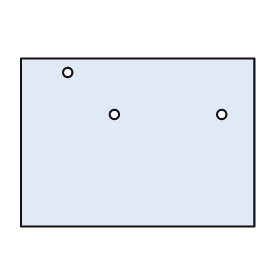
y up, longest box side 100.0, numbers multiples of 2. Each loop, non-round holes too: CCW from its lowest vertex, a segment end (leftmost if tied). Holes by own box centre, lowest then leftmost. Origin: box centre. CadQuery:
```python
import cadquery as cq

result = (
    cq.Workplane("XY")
    .moveTo(-50.0, -36.0)
    .lineTo(50.0, -36.0)
    .lineTo(50.0, 36.0)
    .lineTo(-50.0, 36.0)
    .close()
    .moveTo(-10.0, 12.0)
    .circle(2.0)
    .moveTo(36.0, 12.0)
    .circle(2.0)
    .moveTo(-30.0, 30.0)
    .circle(2.0)
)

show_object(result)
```